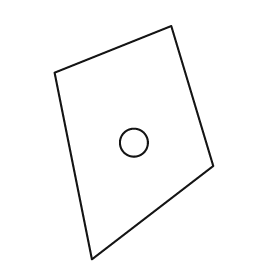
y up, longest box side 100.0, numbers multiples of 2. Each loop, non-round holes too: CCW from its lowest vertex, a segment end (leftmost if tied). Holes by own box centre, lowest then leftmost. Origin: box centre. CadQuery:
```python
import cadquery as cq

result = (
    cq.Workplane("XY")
    .moveTo(-18.0, -50.0)
    .lineTo(34.0, -10.0)
    .lineTo(16.0, 50.0)
    .lineTo(-34.0, 30.0)
    .close()
    .moveTo(0.0, 0.0)
    .circle(6.0)
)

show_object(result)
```